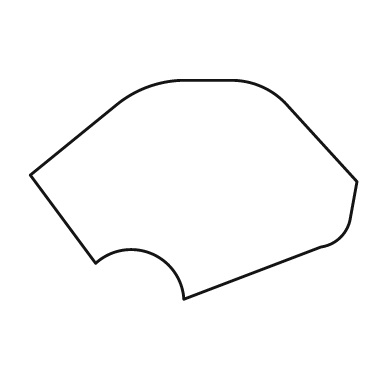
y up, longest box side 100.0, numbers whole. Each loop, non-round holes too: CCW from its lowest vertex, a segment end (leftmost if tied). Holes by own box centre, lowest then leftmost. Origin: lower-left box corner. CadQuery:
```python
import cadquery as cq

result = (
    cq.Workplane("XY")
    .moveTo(47.0, 0.0)
    .lineTo(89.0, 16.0)
    .threePointArc((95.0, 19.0), (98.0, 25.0))
    .lineTo(100.0, 36.0)
    .lineTo(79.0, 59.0)
    .threePointArc((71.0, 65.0), (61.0, 67.0))
    .lineTo(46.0, 67.0)
    .threePointArc((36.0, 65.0), (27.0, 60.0))
    .lineTo(0.0, 38.0)
    .lineTo(20.0, 11.0)
    .threePointArc((37.0, 14.0), (47.0, 0.0))
    .close()
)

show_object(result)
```